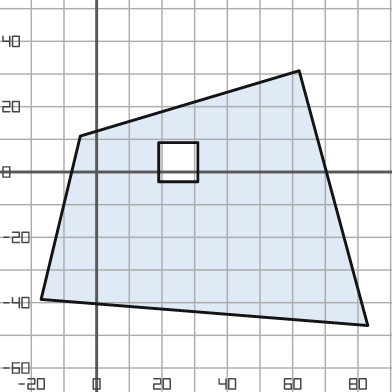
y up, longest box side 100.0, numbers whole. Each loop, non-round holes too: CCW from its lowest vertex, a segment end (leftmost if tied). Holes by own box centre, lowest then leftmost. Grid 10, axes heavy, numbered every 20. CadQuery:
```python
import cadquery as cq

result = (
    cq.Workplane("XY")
    .moveTo(83.0, -47.0)
    .lineTo(62.0, 31.0)
    .lineTo(-5.0, 11.0)
    .lineTo(-17.0, -39.0)
    .close()
    .moveTo(19.0, -3.0)
    .lineTo(31.0, -3.0)
    .lineTo(31.0, 9.0)
    .lineTo(19.0, 9.0)
    .close()
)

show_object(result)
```